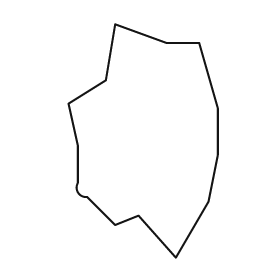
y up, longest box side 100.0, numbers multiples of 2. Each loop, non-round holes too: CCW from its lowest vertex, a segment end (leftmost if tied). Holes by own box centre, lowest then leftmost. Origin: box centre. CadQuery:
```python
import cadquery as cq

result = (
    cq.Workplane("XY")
    .moveTo(14.0, -50.0)
    .lineTo(28.0, -26.0)
    .lineTo(32.0, -6.0)
    .lineTo(32.0, 14.0)
    .lineTo(24.0, 42.0)
    .lineTo(10.0, 42.0)
    .lineTo(-12.0, 50.0)
    .lineTo(-16.0, 26.0)
    .lineTo(-32.0, 16.0)
    .lineTo(-28.0, -2.0)
    .lineTo(-28.0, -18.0)
    .threePointArc((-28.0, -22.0), (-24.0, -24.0))
    .lineTo(-12.0, -36.0)
    .lineTo(-2.0, -32.0)
    .close()
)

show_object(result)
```